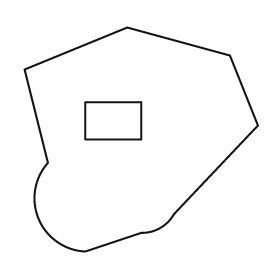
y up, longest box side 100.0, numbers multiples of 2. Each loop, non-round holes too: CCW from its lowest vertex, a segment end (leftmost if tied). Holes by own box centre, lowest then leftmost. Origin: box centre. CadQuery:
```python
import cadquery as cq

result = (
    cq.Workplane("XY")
    .moveTo(-24.0, -48.0)
    .lineTo(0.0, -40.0)
    .threePointArc((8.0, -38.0), (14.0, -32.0))
    .lineTo(50.0, 6.0)
    .lineTo(38.0, 36.0)
    .lineTo(-6.0, 48.0)
    .lineTo(-50.0, 30.0)
    .lineTo(-40.0, -10.0)
    .threePointArc((-44.0, -34.0), (-24.0, -48.0))
    .close()
    .moveTo(-24.0, 0.0)
    .lineTo(0.0, 0.0)
    .lineTo(0.0, 16.0)
    .lineTo(-24.0, 16.0)
    .close()
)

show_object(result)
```